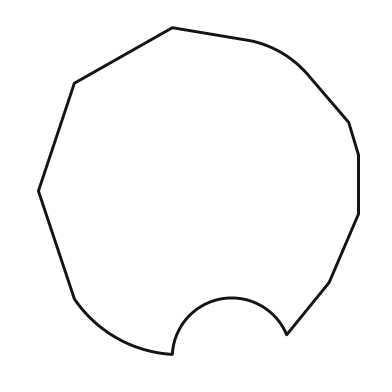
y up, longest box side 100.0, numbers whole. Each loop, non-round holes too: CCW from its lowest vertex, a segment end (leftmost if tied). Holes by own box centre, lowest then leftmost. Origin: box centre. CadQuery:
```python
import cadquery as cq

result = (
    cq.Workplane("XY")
    .moveTo(-8.0, -50.0)
    .threePointArc((7.0, -33.0), (27.0, -44.0))
    .lineTo(40.0, -28.0)
    .lineTo(49.0, -7.0)
    .lineTo(49.0, 11.0)
    .lineTo(46.0, 21.0)
    .lineTo(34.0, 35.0)
    .threePointArc((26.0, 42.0), (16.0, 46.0))
    .lineTo(-8.0, 50.0)
    .lineTo(-38.0, 33.0)
    .lineTo(-49.0, 0.0)
    .lineTo(-38.0, -33.0)
    .threePointArc((-25.0, -45.0), (-8.0, -50.0))
    .close()
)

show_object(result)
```